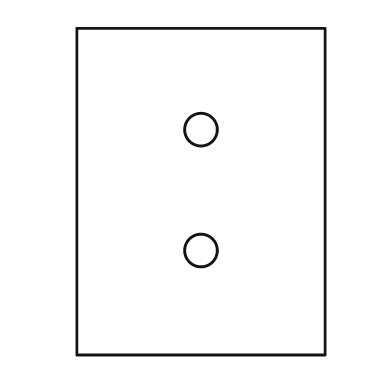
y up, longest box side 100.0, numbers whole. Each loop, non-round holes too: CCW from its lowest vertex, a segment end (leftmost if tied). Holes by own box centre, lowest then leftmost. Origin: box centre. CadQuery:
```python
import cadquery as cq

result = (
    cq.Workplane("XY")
    .moveTo(-38.0, -50.0)
    .lineTo(38.0, -50.0)
    .lineTo(38.0, 50.0)
    .lineTo(-38.0, 50.0)
    .close()
    .moveTo(0.0, -18.0)
    .circle(5.0)
    .moveTo(0.0, 19.0)
    .circle(5.0)
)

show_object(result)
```